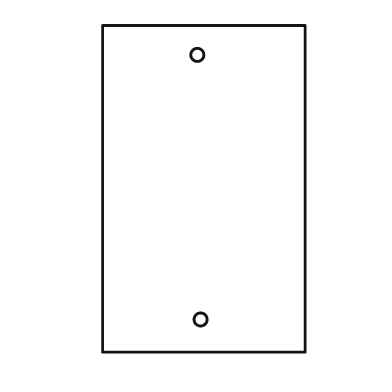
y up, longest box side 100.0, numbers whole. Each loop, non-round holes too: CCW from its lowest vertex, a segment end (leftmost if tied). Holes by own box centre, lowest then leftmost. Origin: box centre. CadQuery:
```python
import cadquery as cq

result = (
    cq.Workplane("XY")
    .moveTo(-31.0, -50.0)
    .lineTo(31.0, -50.0)
    .lineTo(31.0, 50.0)
    .lineTo(-31.0, 50.0)
    .close()
    .moveTo(-1.0, -40.0)
    .circle(2.0)
    .moveTo(-2.0, 41.0)
    .circle(2.0)
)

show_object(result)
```